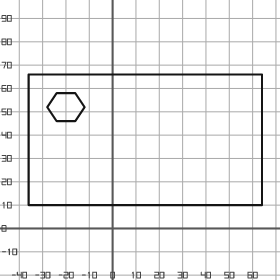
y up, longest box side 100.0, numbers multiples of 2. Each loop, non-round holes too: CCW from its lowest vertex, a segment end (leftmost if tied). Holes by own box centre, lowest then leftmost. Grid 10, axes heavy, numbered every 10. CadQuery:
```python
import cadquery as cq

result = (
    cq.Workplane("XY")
    .moveTo(-36.0, 10.0)
    .lineTo(64.0, 10.0)
    .lineTo(64.0, 66.0)
    .lineTo(-36.0, 66.0)
    .close()
    .moveTo(-24.0, 46.0)
    .lineTo(-16.0, 46.0)
    .lineTo(-12.0, 52.0)
    .lineTo(-16.0, 58.0)
    .lineTo(-24.0, 58.0)
    .lineTo(-28.0, 52.0)
    .close()
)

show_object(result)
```